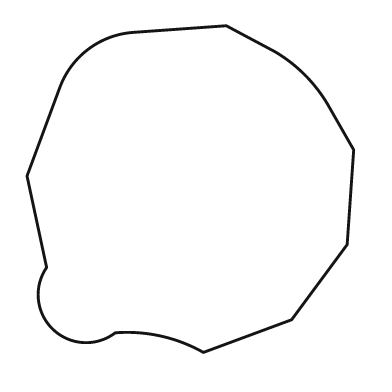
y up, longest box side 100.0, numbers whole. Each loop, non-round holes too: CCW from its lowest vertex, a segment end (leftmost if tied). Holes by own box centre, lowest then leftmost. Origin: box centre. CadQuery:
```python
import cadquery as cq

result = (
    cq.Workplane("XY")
    .moveTo(4.0, -50.0)
    .lineTo(31.0, -40.0)
    .lineTo(48.0, -17.0)
    .lineTo(50.0, 12.0)
    .lineTo(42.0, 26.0)
    .threePointArc((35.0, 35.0), (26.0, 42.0))
    .lineTo(11.0, 50.0)
    .lineTo(-17.0, 48.0)
    .threePointArc((-31.0, 43.0), (-40.0, 31.0))
    .lineTo(-50.0, 4.0)
    .lineTo(-44.0, -24.0)
    .threePointArc((-42.0, -43.0), (-23.0, -44.0))
    .threePointArc((-9.0, -45.0), (4.0, -50.0))
    .close()
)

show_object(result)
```